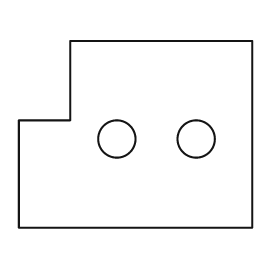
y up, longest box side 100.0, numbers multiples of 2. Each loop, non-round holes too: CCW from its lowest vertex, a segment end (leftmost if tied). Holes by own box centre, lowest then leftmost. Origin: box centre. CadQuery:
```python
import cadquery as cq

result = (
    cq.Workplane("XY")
    .moveTo(-50.0, -40.0)
    .lineTo(50.0, -40.0)
    .lineTo(50.0, 40.0)
    .lineTo(-28.0, 40.0)
    .lineTo(-28.0, 6.0)
    .lineTo(-50.0, 6.0)
    .close()
    .moveTo(-8.0, -2.0)
    .circle(8.0)
    .moveTo(26.0, -2.0)
    .circle(8.0)
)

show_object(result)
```